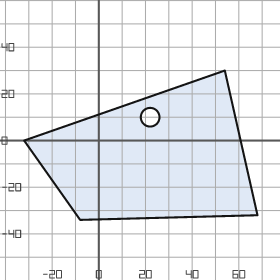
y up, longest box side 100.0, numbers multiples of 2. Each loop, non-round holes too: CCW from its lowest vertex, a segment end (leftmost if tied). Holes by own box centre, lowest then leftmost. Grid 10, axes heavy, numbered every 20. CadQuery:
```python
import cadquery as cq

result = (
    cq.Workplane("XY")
    .moveTo(-8.0, -34.0)
    .lineTo(68.0, -32.0)
    .lineTo(54.0, 30.0)
    .lineTo(-32.0, 0.0)
    .close()
    .moveTo(22.0, 10.0)
    .circle(4.0)
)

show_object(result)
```